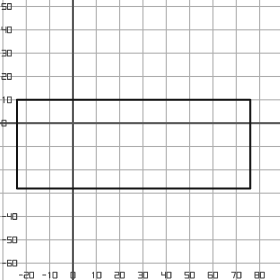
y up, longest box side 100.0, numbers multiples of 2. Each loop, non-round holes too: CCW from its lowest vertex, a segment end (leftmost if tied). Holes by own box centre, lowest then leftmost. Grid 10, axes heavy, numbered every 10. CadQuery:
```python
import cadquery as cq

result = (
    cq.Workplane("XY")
    .moveTo(-24.0, -28.0)
    .lineTo(76.0, -28.0)
    .lineTo(76.0, 10.0)
    .lineTo(-24.0, 10.0)
    .close()
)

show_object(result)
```